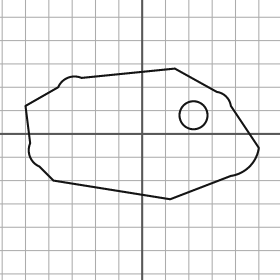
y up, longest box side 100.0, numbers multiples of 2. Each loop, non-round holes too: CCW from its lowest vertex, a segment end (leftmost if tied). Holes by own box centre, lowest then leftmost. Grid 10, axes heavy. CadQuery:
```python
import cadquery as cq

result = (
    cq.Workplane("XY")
    .moveTo(12.0, -28.0)
    .lineTo(38.0, -18.0)
    .threePointArc((46.0, -14.0), (50.0, -6.0))
    .lineTo(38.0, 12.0)
    .threePointArc((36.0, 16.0), (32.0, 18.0))
    .lineTo(14.0, 28.0)
    .lineTo(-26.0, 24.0)
    .threePointArc((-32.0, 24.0), (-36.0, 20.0))
    .lineTo(-50.0, 12.0)
    .lineTo(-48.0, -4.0)
    .threePointArc((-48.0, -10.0), (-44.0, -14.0))
    .lineTo(-38.0, -20.0)
    .close()
    .moveTo(22.0, 8.0)
    .circle(6.0)
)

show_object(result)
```